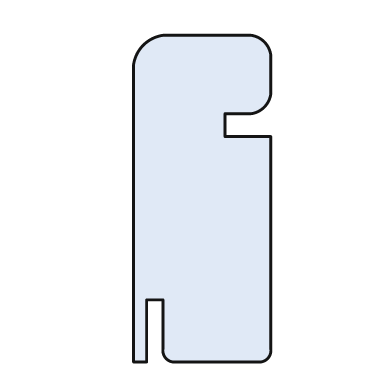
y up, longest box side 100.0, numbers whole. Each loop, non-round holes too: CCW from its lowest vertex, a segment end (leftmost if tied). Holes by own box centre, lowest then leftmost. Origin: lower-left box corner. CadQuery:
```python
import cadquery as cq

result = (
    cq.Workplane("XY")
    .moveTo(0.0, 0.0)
    .lineTo(4.0, 0.0)
    .lineTo(4.0, 19.0)
    .lineTo(9.0, 19.0)
    .lineTo(9.0, 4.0)
    .threePointArc((10.0, 1.0), (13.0, 0.0))
    .lineTo(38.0, 0.0)
    .threePointArc((41.0, 1.0), (42.0, 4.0))
    .lineTo(42.0, 69.0)
    .lineTo(28.0, 69.0)
    .lineTo(28.0, 76.0)
    .lineTo(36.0, 76.0)
    .threePointArc((40.0, 78.0), (42.0, 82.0))
    .lineTo(42.0, 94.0)
    .threePointArc((40.0, 98.0), (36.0, 100.0))
    .lineTo(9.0, 100.0)
    .threePointArc((3.0, 97.0), (0.0, 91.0))
    .close()
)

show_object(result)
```